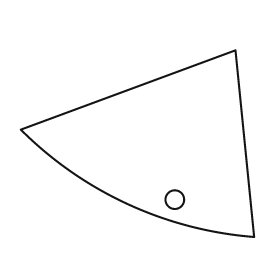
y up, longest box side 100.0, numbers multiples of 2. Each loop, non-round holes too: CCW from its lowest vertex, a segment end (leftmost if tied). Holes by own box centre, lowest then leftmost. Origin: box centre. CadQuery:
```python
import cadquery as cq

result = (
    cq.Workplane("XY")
    .moveTo(50.0, -40.0)
    .lineTo(42.0, 40.0)
    .lineTo(-50.0, 6.0)
    .threePointArc((-4.0, -26.0), (50.0, -40.0))
    .close()
    .moveTo(16.0, -24.0)
    .circle(4.0)
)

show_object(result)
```